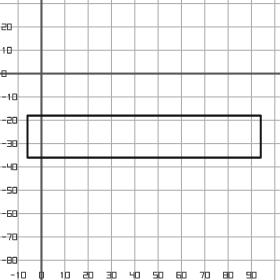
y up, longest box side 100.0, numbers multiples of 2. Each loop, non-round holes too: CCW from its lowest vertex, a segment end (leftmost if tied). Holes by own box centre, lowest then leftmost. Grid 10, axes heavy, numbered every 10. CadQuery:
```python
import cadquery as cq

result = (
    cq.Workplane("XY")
    .moveTo(-6.0, -36.0)
    .lineTo(94.0, -36.0)
    .lineTo(94.0, -18.0)
    .lineTo(-6.0, -18.0)
    .close()
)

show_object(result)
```